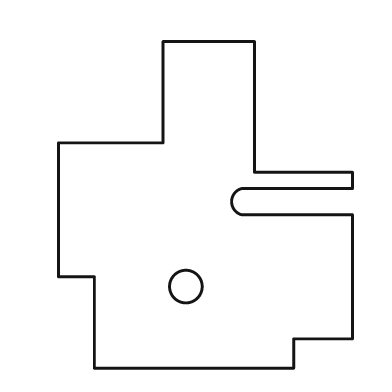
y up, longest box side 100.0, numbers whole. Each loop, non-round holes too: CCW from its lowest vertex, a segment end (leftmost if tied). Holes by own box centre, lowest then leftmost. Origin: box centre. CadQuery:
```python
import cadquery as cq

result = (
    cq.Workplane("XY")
    .moveTo(-34.0, -50.0)
    .lineTo(27.0, -50.0)
    .lineTo(27.0, -41.0)
    .lineTo(45.0, -41.0)
    .lineTo(45.0, -3.0)
    .lineTo(11.0, -3.0)
    .threePointArc((8.0, 1.0), (11.0, 5.0))
    .lineTo(45.0, 5.0)
    .lineTo(45.0, 10.0)
    .lineTo(15.0, 10.0)
    .lineTo(15.0, 50.0)
    .lineTo(-13.0, 50.0)
    .lineTo(-13.0, 19.0)
    .lineTo(-45.0, 19.0)
    .lineTo(-45.0, -22.0)
    .lineTo(-34.0, -22.0)
    .close()
    .moveTo(-6.0, -25.0)
    .circle(5.0)
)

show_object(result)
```